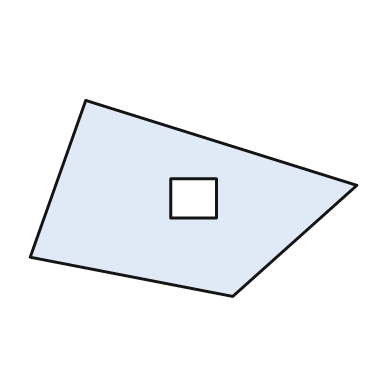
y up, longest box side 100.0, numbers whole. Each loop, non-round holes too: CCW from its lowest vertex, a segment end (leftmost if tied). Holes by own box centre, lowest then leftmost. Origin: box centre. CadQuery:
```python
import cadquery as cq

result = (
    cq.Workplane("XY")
    .moveTo(12.0, -30.0)
    .lineTo(50.0, 4.0)
    .lineTo(-33.0, 30.0)
    .lineTo(-50.0, -18.0)
    .close()
    .moveTo(-7.0, -6.0)
    .lineTo(7.0, -6.0)
    .lineTo(7.0, 6.0)
    .lineTo(-7.0, 6.0)
    .close()
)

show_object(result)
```